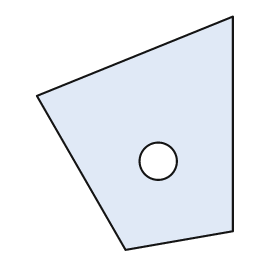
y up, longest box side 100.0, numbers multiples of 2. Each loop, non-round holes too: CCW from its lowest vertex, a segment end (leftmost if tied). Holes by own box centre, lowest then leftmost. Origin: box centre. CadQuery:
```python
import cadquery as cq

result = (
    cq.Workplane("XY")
    .moveTo(-4.0, -50.0)
    .lineTo(42.0, -42.0)
    .lineTo(42.0, 50.0)
    .lineTo(-42.0, 16.0)
    .close()
    .moveTo(10.0, -12.0)
    .circle(8.0)
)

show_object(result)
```